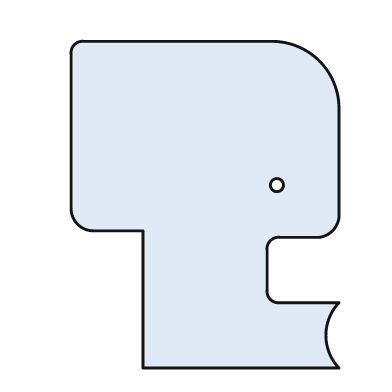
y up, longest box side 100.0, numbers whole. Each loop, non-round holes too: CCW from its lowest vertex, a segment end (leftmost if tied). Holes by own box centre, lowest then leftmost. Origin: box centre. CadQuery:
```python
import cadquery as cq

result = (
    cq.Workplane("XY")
    .moveTo(-19.0, -50.0)
    .lineTo(41.0, -50.0)
    .threePointArc((37.0, -40.0), (41.0, -30.0))
    .lineTo(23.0, -30.0)
    .threePointArc((20.0, -29.0), (19.0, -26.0))
    .lineTo(19.0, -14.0)
    .threePointArc((20.0, -11.0), (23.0, -10.0))
    .lineTo(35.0, -10.0)
    .threePointArc((39.0, -8.0), (41.0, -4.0))
    .lineTo(41.0, 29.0)
    .threePointArc((35.0, 44.0), (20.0, 50.0))
    .lineTo(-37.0, 50.0)
    .threePointArc((-40.0, 49.0), (-41.0, 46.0))
    .lineTo(-41.0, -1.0)
    .threePointArc((-39.0, -6.0), (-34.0, -8.0))
    .lineTo(-19.0, -8.0)
    .close()
    .moveTo(22.0, 6.0)
    .circle(2.0)
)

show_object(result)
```